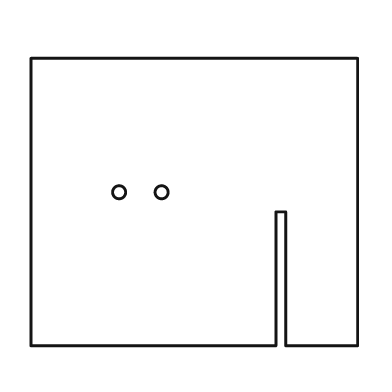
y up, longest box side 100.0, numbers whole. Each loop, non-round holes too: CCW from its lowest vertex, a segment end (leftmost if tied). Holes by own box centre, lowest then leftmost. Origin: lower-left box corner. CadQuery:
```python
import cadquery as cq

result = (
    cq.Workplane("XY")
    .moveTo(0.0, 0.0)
    .lineTo(75.0, 0.0)
    .lineTo(75.0, 41.0)
    .lineTo(78.0, 41.0)
    .lineTo(78.0, 0.0)
    .lineTo(100.0, 0.0)
    .lineTo(100.0, 88.0)
    .lineTo(0.0, 88.0)
    .close()
    .moveTo(27.0, 47.0)
    .circle(2.0)
    .moveTo(40.0, 47.0)
    .circle(2.0)
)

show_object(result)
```